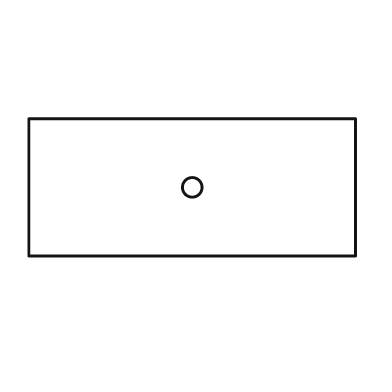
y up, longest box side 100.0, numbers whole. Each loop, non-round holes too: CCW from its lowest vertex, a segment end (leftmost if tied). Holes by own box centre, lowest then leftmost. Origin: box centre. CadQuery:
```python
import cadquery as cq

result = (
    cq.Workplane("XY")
    .moveTo(-50.0, -21.0)
    .lineTo(50.0, -21.0)
    .lineTo(50.0, 21.0)
    .lineTo(-50.0, 21.0)
    .close()
    .moveTo(0.0, 0.0)
    .circle(3.0)
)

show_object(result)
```